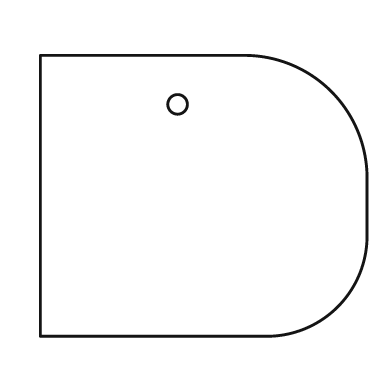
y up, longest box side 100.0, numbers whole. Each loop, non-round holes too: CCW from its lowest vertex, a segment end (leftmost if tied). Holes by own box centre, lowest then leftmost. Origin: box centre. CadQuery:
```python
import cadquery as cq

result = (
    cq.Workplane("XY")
    .moveTo(-50.0, -43.0)
    .lineTo(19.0, -43.0)
    .threePointArc((41.0, -34.0), (50.0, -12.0))
    .lineTo(50.0, 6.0)
    .threePointArc((39.0, 32.0), (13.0, 43.0))
    .lineTo(-50.0, 43.0)
    .close()
    .moveTo(-8.0, 28.0)
    .circle(3.0)
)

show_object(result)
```